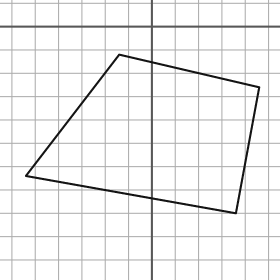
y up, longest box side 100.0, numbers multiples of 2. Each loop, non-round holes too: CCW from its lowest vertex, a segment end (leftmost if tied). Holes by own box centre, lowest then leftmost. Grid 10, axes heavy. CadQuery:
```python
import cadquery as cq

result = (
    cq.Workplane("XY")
    .moveTo(36.0, -80.0)
    .lineTo(46.0, -26.0)
    .lineTo(-14.0, -12.0)
    .lineTo(-54.0, -64.0)
    .close()
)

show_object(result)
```